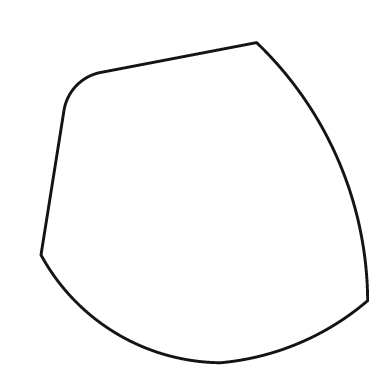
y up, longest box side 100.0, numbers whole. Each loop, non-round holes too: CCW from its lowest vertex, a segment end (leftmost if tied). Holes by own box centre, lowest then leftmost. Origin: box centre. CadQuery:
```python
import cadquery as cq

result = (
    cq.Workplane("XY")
    .moveTo(5.0, -49.0)
    .threePointArc((29.0, -43.0), (50.0, -30.0))
    .threePointArc((41.0, 13.0), (16.0, 49.0))
    .lineTo(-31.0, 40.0)
    .threePointArc((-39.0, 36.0), (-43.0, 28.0))
    .lineTo(-50.0, -16.0)
    .threePointArc((-27.0, -40.0), (5.0, -49.0))
    .close()
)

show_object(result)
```